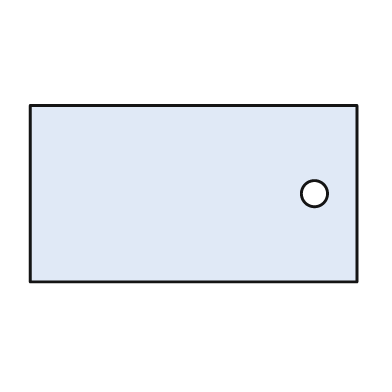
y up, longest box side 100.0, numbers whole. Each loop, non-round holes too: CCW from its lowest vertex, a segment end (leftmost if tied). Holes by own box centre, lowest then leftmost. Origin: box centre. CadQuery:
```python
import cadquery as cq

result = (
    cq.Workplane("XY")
    .moveTo(-50.0, -27.0)
    .lineTo(50.0, -27.0)
    .lineTo(50.0, 27.0)
    .lineTo(-50.0, 27.0)
    .close()
    .moveTo(37.0, 0.0)
    .circle(4.0)
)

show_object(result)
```